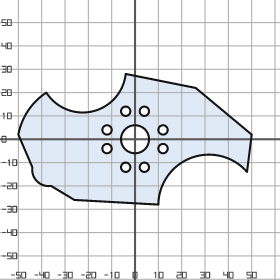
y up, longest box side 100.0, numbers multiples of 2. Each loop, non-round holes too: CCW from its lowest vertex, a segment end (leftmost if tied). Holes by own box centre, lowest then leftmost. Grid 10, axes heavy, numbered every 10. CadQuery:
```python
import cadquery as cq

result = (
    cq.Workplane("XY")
    .moveTo(10.0, -28.0)
    .threePointArc((24.0, -8.0), (48.0, -14.0))
    .lineTo(50.0, 2.0)
    .lineTo(26.0, 22.0)
    .lineTo(-4.0, 28.0)
    .threePointArc((-18.0, 12.0), (-38.0, 20.0))
    .threePointArc((-46.0, 12.0), (-50.0, 2.0))
    .lineTo(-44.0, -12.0)
    .threePointArc((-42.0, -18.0), (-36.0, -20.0))
    .lineTo(-26.0, -26.0)
    .close()
    .moveTo(-4.0, -12.0)
    .circle(2.0)
    .moveTo(4.0, -12.0)
    .circle(2.0)
    .moveTo(-12.0, -4.0)
    .circle(2.0)
    .moveTo(12.0, -4.0)
    .circle(2.0)
    .moveTo(0.0, 0.0)
    .circle(6.0)
    .moveTo(-12.0, 4.0)
    .circle(2.0)
    .moveTo(12.0, 4.0)
    .circle(2.0)
    .moveTo(-4.0, 12.0)
    .circle(2.0)
    .moveTo(4.0, 12.0)
    .circle(2.0)
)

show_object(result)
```